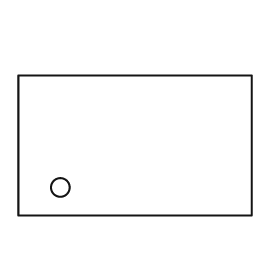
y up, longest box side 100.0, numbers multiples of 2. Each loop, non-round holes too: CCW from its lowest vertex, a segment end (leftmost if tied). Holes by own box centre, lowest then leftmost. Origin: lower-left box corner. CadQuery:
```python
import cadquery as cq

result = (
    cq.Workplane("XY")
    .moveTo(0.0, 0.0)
    .lineTo(100.0, 0.0)
    .lineTo(100.0, 60.0)
    .lineTo(0.0, 60.0)
    .close()
    .moveTo(18.0, 12.0)
    .circle(4.0)
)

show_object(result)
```